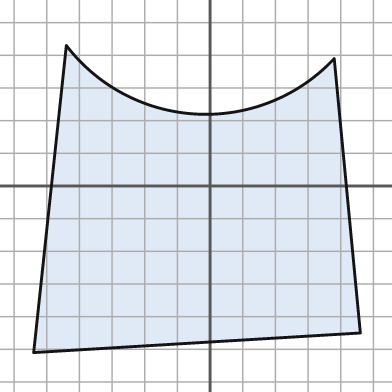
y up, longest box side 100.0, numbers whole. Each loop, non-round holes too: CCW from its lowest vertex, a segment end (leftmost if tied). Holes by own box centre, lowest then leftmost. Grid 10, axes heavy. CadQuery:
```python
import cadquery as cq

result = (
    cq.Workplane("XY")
    .moveTo(-54.0, -51.0)
    .lineTo(46.0, -45.0)
    .lineTo(38.0, 39.0)
    .threePointArc((-4.0, 22.0), (-44.0, 43.0))
    .close()
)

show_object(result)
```